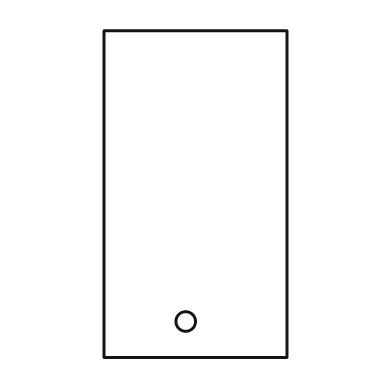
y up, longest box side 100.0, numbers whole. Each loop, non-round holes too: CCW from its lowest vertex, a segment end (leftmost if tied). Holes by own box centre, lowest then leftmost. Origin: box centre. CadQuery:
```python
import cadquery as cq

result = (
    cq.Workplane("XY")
    .moveTo(-28.0, -50.0)
    .lineTo(28.0, -50.0)
    .lineTo(28.0, 50.0)
    .lineTo(-28.0, 50.0)
    .close()
    .moveTo(-3.0, -39.0)
    .circle(3.0)
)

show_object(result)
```